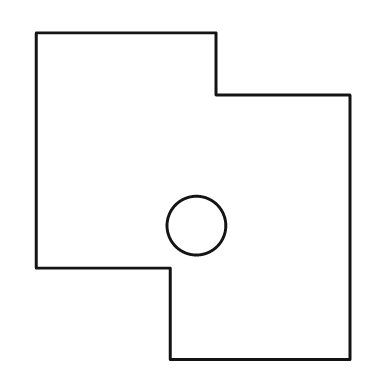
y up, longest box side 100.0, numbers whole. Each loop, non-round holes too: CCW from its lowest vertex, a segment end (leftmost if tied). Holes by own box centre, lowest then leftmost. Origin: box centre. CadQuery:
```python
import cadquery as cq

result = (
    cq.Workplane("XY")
    .moveTo(-7.0, -50.0)
    .lineTo(48.0, -50.0)
    .lineTo(48.0, 31.0)
    .lineTo(7.0, 31.0)
    .lineTo(7.0, 50.0)
    .lineTo(-48.0, 50.0)
    .lineTo(-48.0, -22.0)
    .lineTo(-7.0, -22.0)
    .close()
    .moveTo(1.0, -9.0)
    .circle(9.0)
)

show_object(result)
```